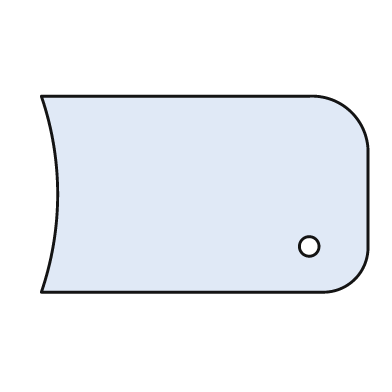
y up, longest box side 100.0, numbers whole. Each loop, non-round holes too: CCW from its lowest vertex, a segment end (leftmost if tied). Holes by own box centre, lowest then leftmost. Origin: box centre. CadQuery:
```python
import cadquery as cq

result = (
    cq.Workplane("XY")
    .moveTo(-50.0, -30.0)
    .lineTo(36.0, -30.0)
    .threePointArc((46.0, -26.0), (50.0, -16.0))
    .lineTo(50.0, 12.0)
    .threePointArc((45.0, 25.0), (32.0, 30.0))
    .lineTo(-50.0, 30.0)
    .threePointArc((-45.0, 0.0), (-50.0, -30.0))
    .close()
    .moveTo(32.0, -16.0)
    .circle(3.0)
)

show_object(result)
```